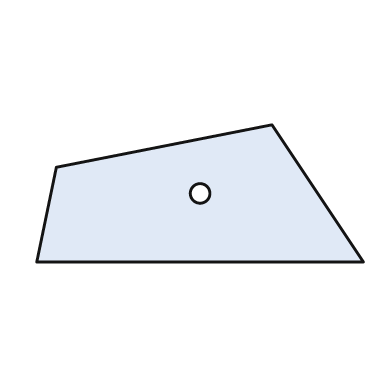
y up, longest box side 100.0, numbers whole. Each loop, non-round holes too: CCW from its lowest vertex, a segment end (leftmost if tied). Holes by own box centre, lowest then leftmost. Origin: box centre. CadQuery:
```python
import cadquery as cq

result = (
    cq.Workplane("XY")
    .moveTo(-50.0, -21.0)
    .lineTo(50.0, -21.0)
    .lineTo(22.0, 21.0)
    .lineTo(-44.0, 8.0)
    .close()
    .moveTo(0.0, 0.0)
    .circle(3.0)
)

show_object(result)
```